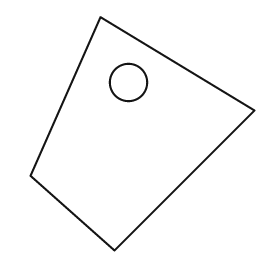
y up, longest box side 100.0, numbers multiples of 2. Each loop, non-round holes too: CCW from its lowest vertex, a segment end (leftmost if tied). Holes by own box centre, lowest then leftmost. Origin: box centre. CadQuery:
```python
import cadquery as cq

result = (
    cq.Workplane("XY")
    .moveTo(-12.0, -50.0)
    .lineTo(48.0, 10.0)
    .lineTo(-18.0, 50.0)
    .lineTo(-48.0, -18.0)
    .close()
    .moveTo(-6.0, 22.0)
    .circle(8.0)
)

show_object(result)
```